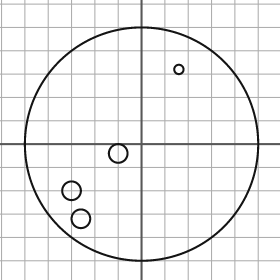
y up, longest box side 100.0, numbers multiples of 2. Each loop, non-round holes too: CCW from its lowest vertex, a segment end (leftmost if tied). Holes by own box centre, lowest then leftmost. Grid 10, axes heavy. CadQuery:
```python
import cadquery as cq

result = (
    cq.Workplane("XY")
    .moveTo(0.0, 0.0)
    .circle(50.0)
    .moveTo(-26.0, -32.0)
    .circle(4.0)
    .moveTo(-30.0, -20.0)
    .circle(4.0)
    .moveTo(-10.0, -4.0)
    .circle(4.0)
    .moveTo(16.0, 32.0)
    .circle(2.0)
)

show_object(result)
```